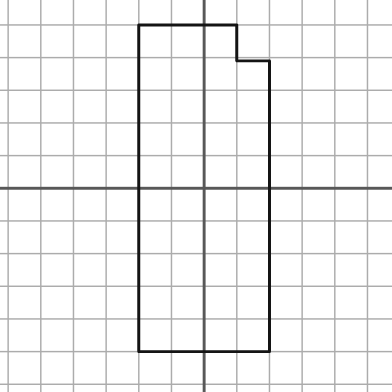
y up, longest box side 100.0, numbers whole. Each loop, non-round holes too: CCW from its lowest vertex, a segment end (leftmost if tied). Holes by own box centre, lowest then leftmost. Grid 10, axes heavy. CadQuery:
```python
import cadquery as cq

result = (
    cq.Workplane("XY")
    .moveTo(-20.0, -50.0)
    .lineTo(20.0, -50.0)
    .lineTo(20.0, 39.0)
    .lineTo(10.0, 39.0)
    .lineTo(10.0, 50.0)
    .lineTo(-20.0, 50.0)
    .close()
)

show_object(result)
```